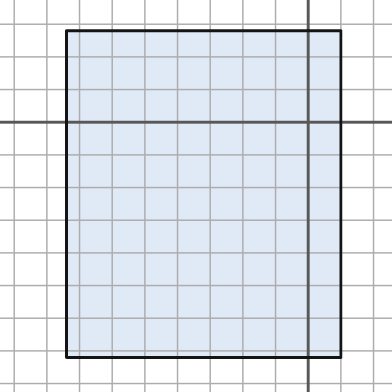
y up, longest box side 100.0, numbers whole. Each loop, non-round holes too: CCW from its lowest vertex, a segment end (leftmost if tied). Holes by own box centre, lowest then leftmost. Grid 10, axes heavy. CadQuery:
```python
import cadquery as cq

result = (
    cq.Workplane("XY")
    .moveTo(-74.0, -72.0)
    .lineTo(10.0, -72.0)
    .lineTo(10.0, 28.0)
    .lineTo(-74.0, 28.0)
    .close()
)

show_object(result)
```